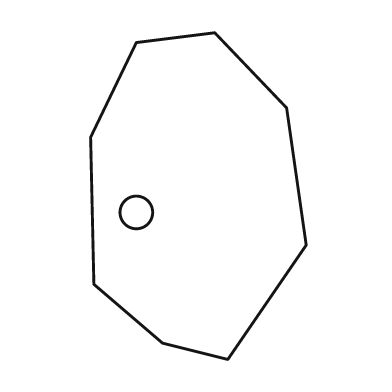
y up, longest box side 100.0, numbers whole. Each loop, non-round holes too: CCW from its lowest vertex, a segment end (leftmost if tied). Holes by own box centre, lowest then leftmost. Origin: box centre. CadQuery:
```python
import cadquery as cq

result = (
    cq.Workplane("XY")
    .moveTo(9.0, -50.0)
    .lineTo(33.0, -15.0)
    .lineTo(27.0, 27.0)
    .lineTo(5.0, 50.0)
    .lineTo(-19.0, 47.0)
    .lineTo(-33.0, 18.0)
    .lineTo(-32.0, -27.0)
    .lineTo(-11.0, -45.0)
    .close()
    .moveTo(-19.0, -5.0)
    .circle(5.0)
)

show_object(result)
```